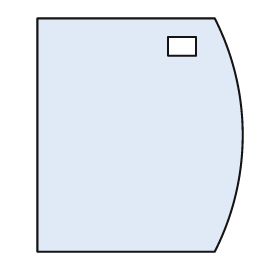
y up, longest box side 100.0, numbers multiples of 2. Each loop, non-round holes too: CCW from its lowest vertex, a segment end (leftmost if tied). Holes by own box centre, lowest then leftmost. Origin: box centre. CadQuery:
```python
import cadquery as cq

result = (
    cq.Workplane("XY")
    .moveTo(-44.0, -50.0)
    .lineTo(32.0, -50.0)
    .threePointArc((44.0, 0.0), (32.0, 50.0))
    .lineTo(-44.0, 50.0)
    .close()
    .moveTo(12.0, 34.0)
    .lineTo(24.0, 34.0)
    .lineTo(24.0, 42.0)
    .lineTo(12.0, 42.0)
    .close()
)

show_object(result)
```